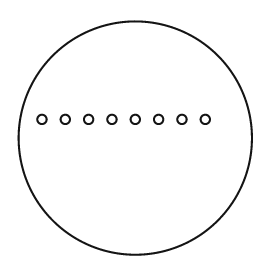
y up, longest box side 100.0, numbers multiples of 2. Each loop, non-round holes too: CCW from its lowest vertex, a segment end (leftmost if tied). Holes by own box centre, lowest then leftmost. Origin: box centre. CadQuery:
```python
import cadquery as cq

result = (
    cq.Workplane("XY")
    .moveTo(0.0, 0.0)
    .circle(50.0)
    .moveTo(-40.0, 8.0)
    .circle(2.0)
    .moveTo(-30.0, 8.0)
    .circle(2.0)
    .moveTo(-20.0, 8.0)
    .circle(2.0)
    .moveTo(-10.0, 8.0)
    .circle(2.0)
    .moveTo(0.0, 8.0)
    .circle(2.0)
    .moveTo(10.0, 8.0)
    .circle(2.0)
    .moveTo(20.0, 8.0)
    .circle(2.0)
    .moveTo(30.0, 8.0)
    .circle(2.0)
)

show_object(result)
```